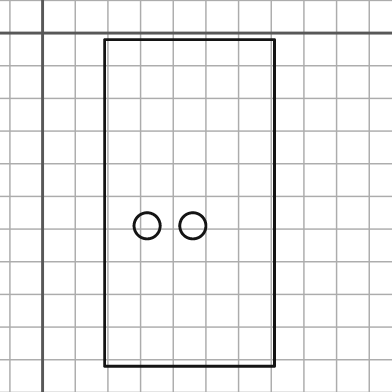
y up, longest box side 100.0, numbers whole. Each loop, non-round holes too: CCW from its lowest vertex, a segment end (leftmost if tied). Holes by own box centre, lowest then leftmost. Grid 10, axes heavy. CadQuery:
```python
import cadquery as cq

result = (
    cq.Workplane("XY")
    .moveTo(19.0, -102.0)
    .lineTo(71.0, -102.0)
    .lineTo(71.0, -2.0)
    .lineTo(19.0, -2.0)
    .close()
    .moveTo(32.0, -59.0)
    .circle(4.0)
    .moveTo(46.0, -59.0)
    .circle(4.0)
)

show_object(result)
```